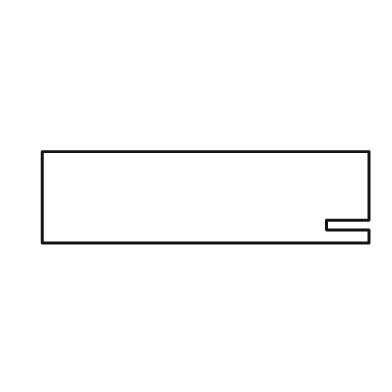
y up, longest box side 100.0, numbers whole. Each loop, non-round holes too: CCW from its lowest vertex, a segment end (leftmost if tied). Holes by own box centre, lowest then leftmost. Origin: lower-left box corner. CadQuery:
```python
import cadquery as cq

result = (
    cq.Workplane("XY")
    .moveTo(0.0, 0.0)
    .lineTo(100.0, 0.0)
    .lineTo(100.0, 4.0)
    .lineTo(87.0, 4.0)
    .lineTo(87.0, 7.0)
    .lineTo(100.0, 7.0)
    .lineTo(100.0, 28.0)
    .lineTo(0.0, 28.0)
    .close()
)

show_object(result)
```